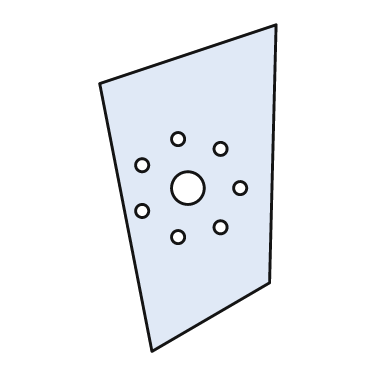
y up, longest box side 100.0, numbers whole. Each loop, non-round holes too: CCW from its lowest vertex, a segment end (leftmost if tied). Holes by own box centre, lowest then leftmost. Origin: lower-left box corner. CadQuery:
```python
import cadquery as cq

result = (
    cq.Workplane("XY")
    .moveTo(16.0, 0.0)
    .lineTo(52.0, 21.0)
    .lineTo(54.0, 100.0)
    .lineTo(0.0, 82.0)
    .close()
    .moveTo(24.0, 35.0)
    .circle(2.0)
    .moveTo(37.0, 38.0)
    .circle(2.0)
    .moveTo(13.0, 43.0)
    .circle(2.0)
    .moveTo(27.0, 50.0)
    .circle(5.0)
    .moveTo(43.0, 50.0)
    .circle(2.0)
    .moveTo(13.0, 57.0)
    .circle(2.0)
    .moveTo(37.0, 62.0)
    .circle(2.0)
    .moveTo(24.0, 65.0)
    .circle(2.0)
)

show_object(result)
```